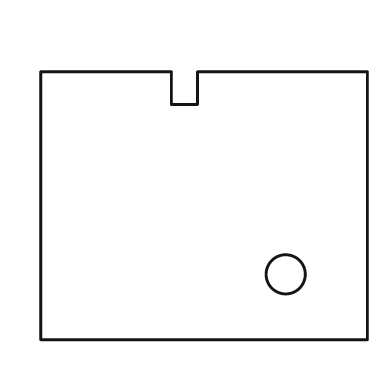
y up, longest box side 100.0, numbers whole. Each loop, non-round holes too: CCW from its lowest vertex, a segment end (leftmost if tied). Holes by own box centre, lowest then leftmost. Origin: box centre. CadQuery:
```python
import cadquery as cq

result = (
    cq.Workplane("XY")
    .moveTo(-50.0, -41.0)
    .lineTo(50.0, -41.0)
    .lineTo(50.0, 41.0)
    .lineTo(-2.0, 41.0)
    .lineTo(-2.0, 31.0)
    .lineTo(-10.0, 31.0)
    .lineTo(-10.0, 41.0)
    .lineTo(-50.0, 41.0)
    .close()
    .moveTo(25.0, -21.0)
    .circle(6.0)
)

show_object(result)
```